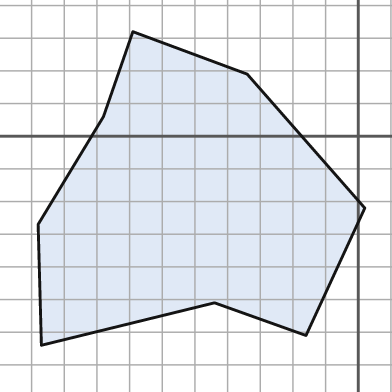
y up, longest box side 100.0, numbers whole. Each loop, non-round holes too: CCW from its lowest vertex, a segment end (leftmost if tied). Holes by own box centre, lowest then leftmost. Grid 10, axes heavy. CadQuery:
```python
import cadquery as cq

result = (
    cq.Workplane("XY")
    .moveTo(-97.0, -64.0)
    .lineTo(-44.0, -51.0)
    .lineTo(-16.0, -61.0)
    .lineTo(2.0, -22.0)
    .lineTo(-34.0, 19.0)
    .lineTo(-69.0, 32.0)
    .lineTo(-78.0, 6.0)
    .lineTo(-98.0, -27.0)
    .close()
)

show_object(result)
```